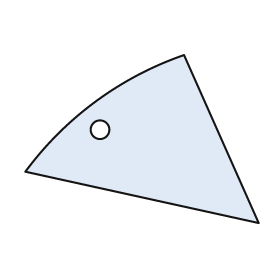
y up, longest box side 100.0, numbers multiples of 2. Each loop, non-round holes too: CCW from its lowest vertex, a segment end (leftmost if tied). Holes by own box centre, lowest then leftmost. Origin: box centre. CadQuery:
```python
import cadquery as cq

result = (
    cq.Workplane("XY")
    .moveTo(50.0, -36.0)
    .lineTo(18.0, 36.0)
    .threePointArc((-20.0, 16.0), (-50.0, -14.0))
    .close()
    .moveTo(-18.0, 4.0)
    .circle(4.0)
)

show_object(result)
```